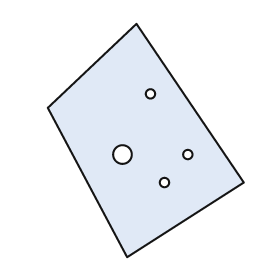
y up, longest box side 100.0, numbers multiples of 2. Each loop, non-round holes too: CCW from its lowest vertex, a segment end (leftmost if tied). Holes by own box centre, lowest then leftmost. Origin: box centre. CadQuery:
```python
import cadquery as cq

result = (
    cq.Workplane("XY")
    .moveTo(-8.0, -50.0)
    .lineTo(42.0, -18.0)
    .lineTo(-4.0, 50.0)
    .lineTo(-42.0, 14.0)
    .close()
    .moveTo(8.0, -18.0)
    .circle(2.0)
    .moveTo(-10.0, -6.0)
    .circle(4.0)
    .moveTo(18.0, -6.0)
    .circle(2.0)
    .moveTo(2.0, 20.0)
    .circle(2.0)
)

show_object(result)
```